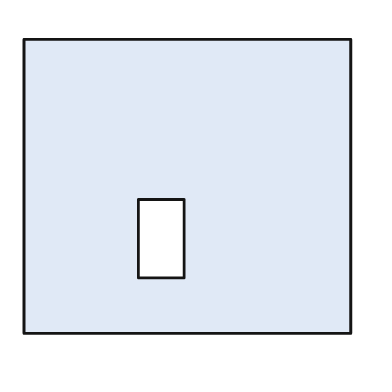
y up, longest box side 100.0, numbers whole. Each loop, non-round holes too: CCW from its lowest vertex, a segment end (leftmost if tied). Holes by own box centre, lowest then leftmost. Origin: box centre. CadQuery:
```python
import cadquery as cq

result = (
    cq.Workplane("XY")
    .moveTo(-50.0, -45.0)
    .lineTo(50.0, -45.0)
    .lineTo(50.0, 45.0)
    .lineTo(-50.0, 45.0)
    .close()
    .moveTo(-15.0, -28.0)
    .lineTo(-1.0, -28.0)
    .lineTo(-1.0, -4.0)
    .lineTo(-15.0, -4.0)
    .close()
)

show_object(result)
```